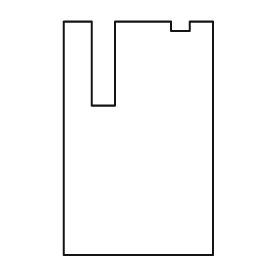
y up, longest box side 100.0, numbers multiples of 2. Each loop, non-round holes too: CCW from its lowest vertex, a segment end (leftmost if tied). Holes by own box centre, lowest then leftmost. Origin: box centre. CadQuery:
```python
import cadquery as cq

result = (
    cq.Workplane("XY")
    .moveTo(-32.0, -50.0)
    .lineTo(32.0, -50.0)
    .lineTo(32.0, 50.0)
    .lineTo(22.0, 50.0)
    .lineTo(22.0, 46.0)
    .lineTo(14.0, 46.0)
    .lineTo(14.0, 50.0)
    .lineTo(-10.0, 50.0)
    .lineTo(-10.0, 14.0)
    .lineTo(-20.0, 14.0)
    .lineTo(-20.0, 50.0)
    .lineTo(-32.0, 50.0)
    .close()
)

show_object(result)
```